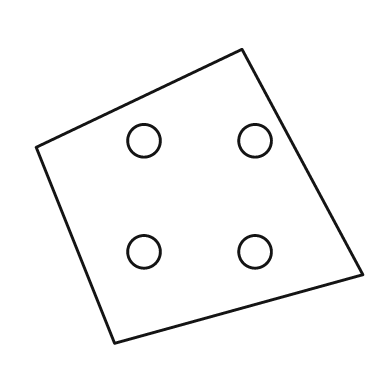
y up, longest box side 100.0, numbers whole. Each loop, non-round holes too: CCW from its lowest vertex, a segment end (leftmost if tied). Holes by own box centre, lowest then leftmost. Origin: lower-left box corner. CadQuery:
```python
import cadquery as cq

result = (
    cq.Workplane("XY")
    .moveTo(24.0, 0.0)
    .lineTo(100.0, 21.0)
    .lineTo(63.0, 90.0)
    .lineTo(0.0, 60.0)
    .close()
    .moveTo(33.0, 28.0)
    .circle(5.0)
    .moveTo(67.0, 28.0)
    .circle(5.0)
    .moveTo(33.0, 62.0)
    .circle(5.0)
    .moveTo(67.0, 62.0)
    .circle(5.0)
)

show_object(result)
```